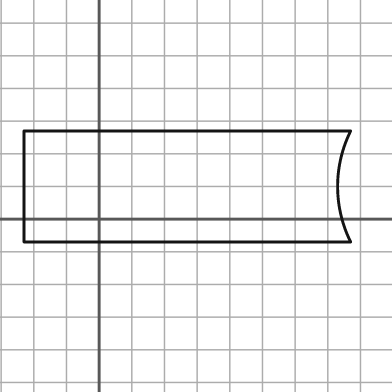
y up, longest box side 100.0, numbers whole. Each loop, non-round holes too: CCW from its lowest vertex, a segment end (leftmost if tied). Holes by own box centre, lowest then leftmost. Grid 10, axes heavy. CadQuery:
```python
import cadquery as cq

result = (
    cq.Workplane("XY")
    .moveTo(-23.0, -7.0)
    .lineTo(77.0, -7.0)
    .threePointArc((73.0, 10.0), (77.0, 27.0))
    .lineTo(-23.0, 27.0)
    .close()
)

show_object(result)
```